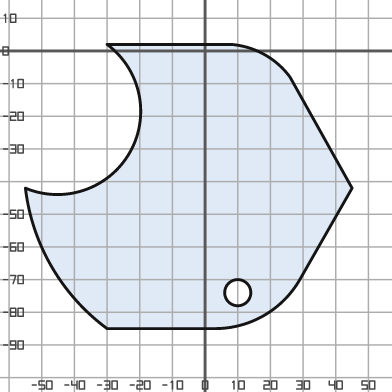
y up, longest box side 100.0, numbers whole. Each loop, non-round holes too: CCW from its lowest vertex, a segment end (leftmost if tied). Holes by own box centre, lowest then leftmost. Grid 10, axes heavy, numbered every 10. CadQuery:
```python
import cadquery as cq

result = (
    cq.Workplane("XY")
    .moveTo(-30.0, -85.0)
    .lineTo(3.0, -85.0)
    .threePointArc((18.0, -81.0), (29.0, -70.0))
    .lineTo(45.0, -42.0)
    .lineTo(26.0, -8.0)
    .threePointArc((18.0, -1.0), (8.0, 2.0))
    .lineTo(-30.0, 2.0)
    .threePointArc((-23.0, -31.0), (-55.0, -42.0))
    .threePointArc((-47.0, -66.0), (-30.0, -85.0))
    .close()
    .moveTo(10.0, -74.0)
    .circle(4.0)
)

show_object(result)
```